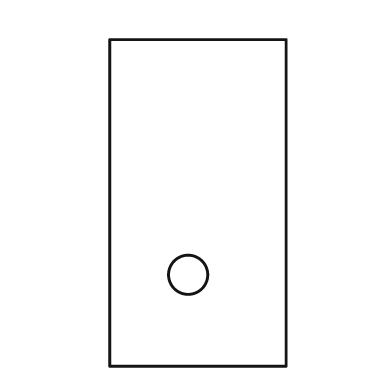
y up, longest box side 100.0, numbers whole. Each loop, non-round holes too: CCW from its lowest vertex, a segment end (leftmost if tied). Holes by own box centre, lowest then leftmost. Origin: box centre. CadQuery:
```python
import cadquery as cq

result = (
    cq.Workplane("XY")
    .moveTo(-27.0, -50.0)
    .lineTo(27.0, -50.0)
    .lineTo(27.0, 50.0)
    .lineTo(-27.0, 50.0)
    .close()
    .moveTo(-3.0, -22.0)
    .circle(6.0)
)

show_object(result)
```